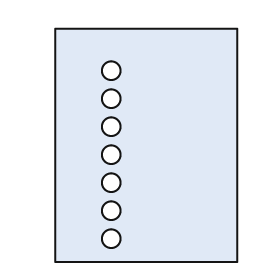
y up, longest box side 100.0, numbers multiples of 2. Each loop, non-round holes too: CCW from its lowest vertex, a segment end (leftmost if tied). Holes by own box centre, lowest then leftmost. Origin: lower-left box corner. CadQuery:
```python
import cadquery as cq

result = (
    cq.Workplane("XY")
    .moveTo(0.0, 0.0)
    .lineTo(78.0, 0.0)
    .lineTo(78.0, 100.0)
    .lineTo(0.0, 100.0)
    .close()
    .moveTo(24.0, 10.0)
    .circle(4.0)
    .moveTo(24.0, 22.0)
    .circle(4.0)
    .moveTo(24.0, 34.0)
    .circle(4.0)
    .moveTo(24.0, 46.0)
    .circle(4.0)
    .moveTo(24.0, 58.0)
    .circle(4.0)
    .moveTo(24.0, 70.0)
    .circle(4.0)
    .moveTo(24.0, 82.0)
    .circle(4.0)
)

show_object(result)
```